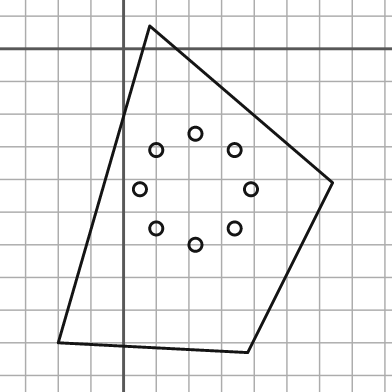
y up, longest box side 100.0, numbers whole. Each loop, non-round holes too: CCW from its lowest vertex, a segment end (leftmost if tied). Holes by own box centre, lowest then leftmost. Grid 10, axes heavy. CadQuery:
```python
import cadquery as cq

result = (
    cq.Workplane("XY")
    .moveTo(38.0, -93.0)
    .lineTo(64.0, -41.0)
    .lineTo(8.0, 7.0)
    .lineTo(-20.0, -90.0)
    .close()
    .moveTo(22.0, -60.0)
    .circle(2.0)
    .moveTo(10.0, -55.0)
    .circle(2.0)
    .moveTo(34.0, -55.0)
    .circle(2.0)
    .moveTo(5.0, -43.0)
    .circle(2.0)
    .moveTo(39.0, -43.0)
    .circle(2.0)
    .moveTo(10.0, -31.0)
    .circle(2.0)
    .moveTo(34.0, -31.0)
    .circle(2.0)
    .moveTo(22.0, -26.0)
    .circle(2.0)
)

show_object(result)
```